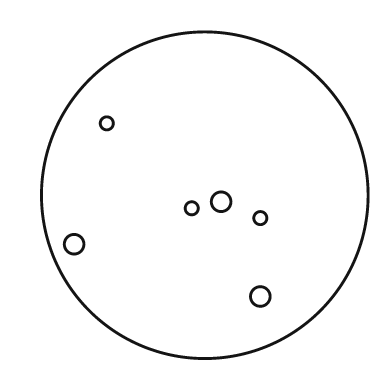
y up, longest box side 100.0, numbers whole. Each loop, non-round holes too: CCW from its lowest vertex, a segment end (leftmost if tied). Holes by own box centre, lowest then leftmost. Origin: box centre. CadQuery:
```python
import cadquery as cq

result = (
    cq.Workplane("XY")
    .moveTo(0.0, 0.0)
    .circle(50.0)
    .moveTo(17.0, -31.0)
    .circle(3.0)
    .moveTo(-40.0, -15.0)
    .circle(3.0)
    .moveTo(17.0, -7.0)
    .circle(2.0)
    .moveTo(-4.0, -4.0)
    .circle(2.0)
    .moveTo(5.0, -2.0)
    .circle(3.0)
    .moveTo(-30.0, 22.0)
    .circle(2.0)
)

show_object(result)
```